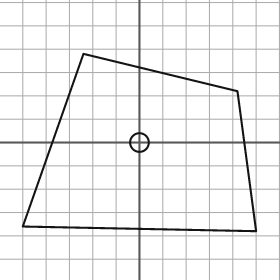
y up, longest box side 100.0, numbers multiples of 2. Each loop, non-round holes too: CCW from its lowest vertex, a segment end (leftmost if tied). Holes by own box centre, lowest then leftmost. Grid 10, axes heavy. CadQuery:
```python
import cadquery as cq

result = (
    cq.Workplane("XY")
    .moveTo(50.0, -38.0)
    .lineTo(42.0, 22.0)
    .lineTo(-24.0, 38.0)
    .lineTo(-50.0, -36.0)
    .close()
    .moveTo(0.0, 0.0)
    .circle(4.0)
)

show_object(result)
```